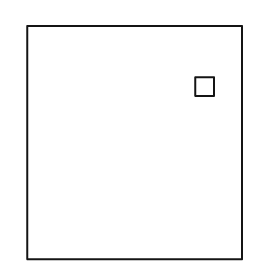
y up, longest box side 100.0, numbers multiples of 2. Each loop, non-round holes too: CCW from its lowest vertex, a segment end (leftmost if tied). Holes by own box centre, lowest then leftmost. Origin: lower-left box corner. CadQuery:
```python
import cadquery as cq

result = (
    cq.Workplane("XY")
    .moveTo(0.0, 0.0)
    .lineTo(92.0, 0.0)
    .lineTo(92.0, 100.0)
    .lineTo(0.0, 100.0)
    .close()
    .moveTo(72.0, 70.0)
    .lineTo(80.0, 70.0)
    .lineTo(80.0, 78.0)
    .lineTo(72.0, 78.0)
    .close()
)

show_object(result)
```